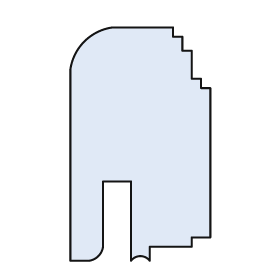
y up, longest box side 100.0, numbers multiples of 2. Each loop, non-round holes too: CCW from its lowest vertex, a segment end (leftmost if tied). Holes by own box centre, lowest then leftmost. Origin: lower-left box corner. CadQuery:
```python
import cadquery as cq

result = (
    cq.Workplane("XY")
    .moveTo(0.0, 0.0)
    .lineTo(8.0, 0.0)
    .threePointArc((12.0, 2.0), (14.0, 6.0))
    .lineTo(14.0, 34.0)
    .lineTo(26.0, 34.0)
    .lineTo(26.0, 0.0)
    .threePointArc((30.0, 2.0), (34.0, 0.0))
    .lineTo(34.0, 6.0)
    .lineTo(52.0, 6.0)
    .lineTo(52.0, 10.0)
    .lineTo(60.0, 10.0)
    .lineTo(60.0, 74.0)
    .lineTo(56.0, 74.0)
    .lineTo(56.0, 78.0)
    .lineTo(52.0, 78.0)
    .lineTo(52.0, 90.0)
    .lineTo(48.0, 90.0)
    .lineTo(48.0, 96.0)
    .lineTo(44.0, 96.0)
    .lineTo(44.0, 100.0)
    .lineTo(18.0, 100.0)
    .threePointArc((6.0, 94.0), (0.0, 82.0))
    .close()
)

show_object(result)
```